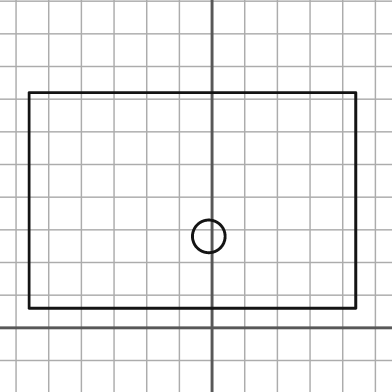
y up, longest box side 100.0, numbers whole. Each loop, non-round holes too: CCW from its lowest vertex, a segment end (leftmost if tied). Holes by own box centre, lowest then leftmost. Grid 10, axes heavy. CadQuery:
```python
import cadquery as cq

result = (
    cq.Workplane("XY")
    .moveTo(-56.0, 6.0)
    .lineTo(44.0, 6.0)
    .lineTo(44.0, 72.0)
    .lineTo(-56.0, 72.0)
    .close()
    .moveTo(-1.0, 28.0)
    .circle(5.0)
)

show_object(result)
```